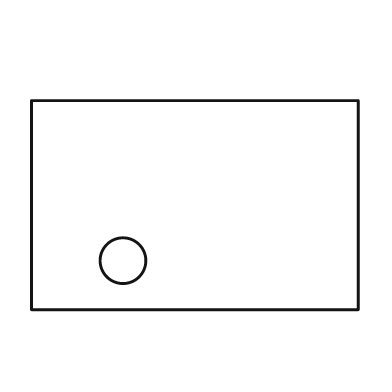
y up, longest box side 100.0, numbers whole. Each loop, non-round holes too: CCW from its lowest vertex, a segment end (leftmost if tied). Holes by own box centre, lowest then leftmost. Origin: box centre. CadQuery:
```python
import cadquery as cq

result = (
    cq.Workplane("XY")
    .moveTo(-50.0, -32.0)
    .lineTo(50.0, -32.0)
    .lineTo(50.0, 32.0)
    .lineTo(-50.0, 32.0)
    .close()
    .moveTo(-22.0, -17.0)
    .circle(7.0)
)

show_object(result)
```